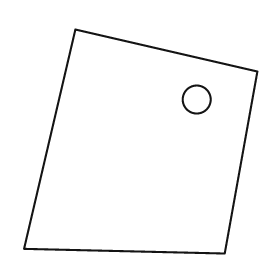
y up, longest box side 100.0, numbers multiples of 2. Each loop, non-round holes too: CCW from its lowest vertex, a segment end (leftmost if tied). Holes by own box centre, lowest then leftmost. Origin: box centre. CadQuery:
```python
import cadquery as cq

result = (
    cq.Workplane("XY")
    .moveTo(36.0, -48.0)
    .lineTo(50.0, 30.0)
    .lineTo(-28.0, 48.0)
    .lineTo(-50.0, -46.0)
    .close()
    .moveTo(24.0, 18.0)
    .circle(6.0)
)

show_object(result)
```